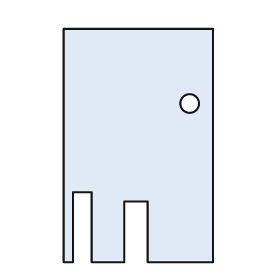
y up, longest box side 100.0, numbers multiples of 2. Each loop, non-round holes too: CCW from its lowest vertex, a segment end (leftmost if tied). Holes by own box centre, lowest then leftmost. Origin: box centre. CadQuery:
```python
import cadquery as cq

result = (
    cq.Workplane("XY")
    .moveTo(-32.0, -50.0)
    .lineTo(-28.0, -50.0)
    .lineTo(-28.0, -20.0)
    .lineTo(-20.0, -20.0)
    .lineTo(-20.0, -50.0)
    .lineTo(-6.0, -50.0)
    .lineTo(-6.0, -24.0)
    .lineTo(4.0, -24.0)
    .lineTo(4.0, -50.0)
    .lineTo(32.0, -50.0)
    .lineTo(32.0, 50.0)
    .lineTo(-32.0, 50.0)
    .close()
    .moveTo(22.0, 18.0)
    .circle(4.0)
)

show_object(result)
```